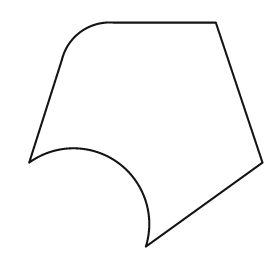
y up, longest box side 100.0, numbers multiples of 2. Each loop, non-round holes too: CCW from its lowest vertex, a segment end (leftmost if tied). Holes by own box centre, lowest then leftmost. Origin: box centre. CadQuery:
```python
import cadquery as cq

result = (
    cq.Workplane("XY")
    .moveTo(0.0, -48.0)
    .lineTo(50.0, -12.0)
    .lineTo(30.0, 48.0)
    .lineTo(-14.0, 48.0)
    .threePointArc((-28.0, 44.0), (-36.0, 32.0))
    .lineTo(-50.0, -12.0)
    .threePointArc((-12.0, -12.0), (0.0, -48.0))
    .close()
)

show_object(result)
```